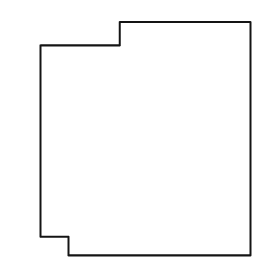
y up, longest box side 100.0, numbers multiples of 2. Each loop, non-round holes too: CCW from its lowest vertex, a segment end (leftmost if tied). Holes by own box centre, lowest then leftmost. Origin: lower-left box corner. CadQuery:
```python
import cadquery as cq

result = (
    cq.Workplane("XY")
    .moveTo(12.0, 0.0)
    .lineTo(90.0, 0.0)
    .lineTo(90.0, 100.0)
    .lineTo(34.0, 100.0)
    .lineTo(34.0, 90.0)
    .lineTo(0.0, 90.0)
    .lineTo(0.0, 8.0)
    .lineTo(12.0, 8.0)
    .close()
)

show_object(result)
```